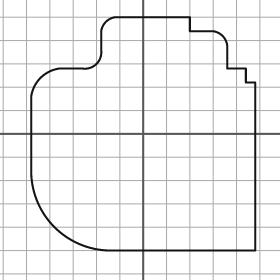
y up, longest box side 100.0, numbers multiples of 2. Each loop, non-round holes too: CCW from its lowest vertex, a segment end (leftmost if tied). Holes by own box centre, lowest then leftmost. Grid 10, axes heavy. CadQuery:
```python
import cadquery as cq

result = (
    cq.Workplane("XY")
    .moveTo(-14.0, -50.0)
    .lineTo(48.0, -50.0)
    .lineTo(48.0, 22.0)
    .lineTo(44.0, 22.0)
    .lineTo(44.0, 28.0)
    .lineTo(36.0, 28.0)
    .lineTo(36.0, 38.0)
    .threePointArc((34.0, 42.0), (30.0, 44.0))
    .lineTo(20.0, 44.0)
    .lineTo(20.0, 50.0)
    .lineTo(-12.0, 50.0)
    .threePointArc((-16.0, 48.0), (-18.0, 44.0))
    .lineTo(-18.0, 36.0)
    .threePointArc((-20.0, 30.0), (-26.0, 28.0))
    .lineTo(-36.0, 28.0)
    .threePointArc((-44.0, 24.0), (-48.0, 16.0))
    .lineTo(-48.0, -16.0)
    .threePointArc((-38.0, -40.0), (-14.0, -50.0))
    .close()
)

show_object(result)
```